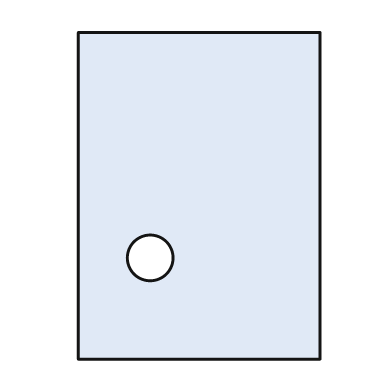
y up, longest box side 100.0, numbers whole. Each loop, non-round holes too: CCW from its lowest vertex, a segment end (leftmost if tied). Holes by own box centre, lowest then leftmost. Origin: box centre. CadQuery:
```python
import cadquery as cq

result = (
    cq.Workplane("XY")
    .moveTo(-37.0, -50.0)
    .lineTo(37.0, -50.0)
    .lineTo(37.0, 50.0)
    .lineTo(-37.0, 50.0)
    .close()
    .moveTo(-15.0, -19.0)
    .circle(7.0)
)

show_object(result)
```